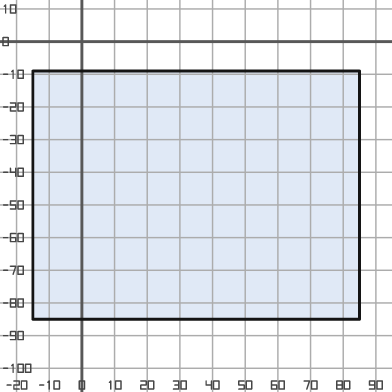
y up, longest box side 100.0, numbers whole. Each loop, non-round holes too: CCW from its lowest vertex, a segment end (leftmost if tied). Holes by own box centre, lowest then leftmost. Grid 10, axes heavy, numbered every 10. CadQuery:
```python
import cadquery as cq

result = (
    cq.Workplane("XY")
    .moveTo(-15.0, -85.0)
    .lineTo(85.0, -85.0)
    .lineTo(85.0, -9.0)
    .lineTo(-15.0, -9.0)
    .close()
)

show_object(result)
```